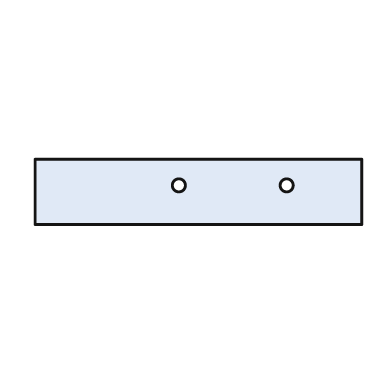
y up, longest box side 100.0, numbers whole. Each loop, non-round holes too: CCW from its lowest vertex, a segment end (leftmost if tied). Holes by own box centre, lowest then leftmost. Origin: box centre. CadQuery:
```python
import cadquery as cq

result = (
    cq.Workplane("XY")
    .moveTo(-50.0, -10.0)
    .lineTo(50.0, -10.0)
    .lineTo(50.0, 10.0)
    .lineTo(-50.0, 10.0)
    .close()
    .moveTo(-6.0, 2.0)
    .circle(2.0)
    .moveTo(27.0, 2.0)
    .circle(2.0)
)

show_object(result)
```